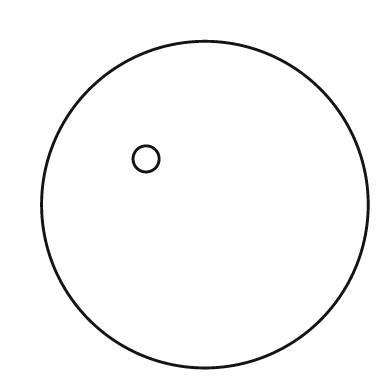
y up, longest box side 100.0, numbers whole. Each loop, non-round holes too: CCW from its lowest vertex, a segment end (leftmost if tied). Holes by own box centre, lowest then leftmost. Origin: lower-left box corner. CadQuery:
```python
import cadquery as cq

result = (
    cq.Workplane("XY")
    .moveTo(50.0, 50.0)
    .circle(50.0)
    .moveTo(32.0, 64.0)
    .circle(4.0)
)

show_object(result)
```